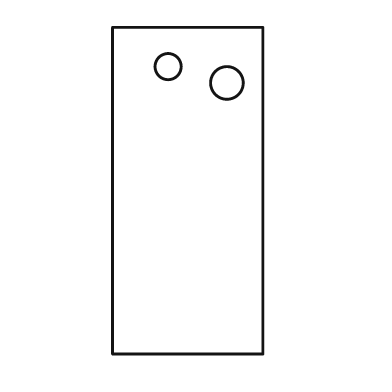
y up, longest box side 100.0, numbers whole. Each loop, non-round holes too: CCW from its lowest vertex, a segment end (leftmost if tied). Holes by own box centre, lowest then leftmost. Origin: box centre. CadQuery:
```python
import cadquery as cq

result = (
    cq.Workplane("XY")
    .moveTo(-23.0, -50.0)
    .lineTo(23.0, -50.0)
    .lineTo(23.0, 50.0)
    .lineTo(-23.0, 50.0)
    .close()
    .moveTo(12.0, 33.0)
    .circle(5.0)
    .moveTo(-6.0, 38.0)
    .circle(4.0)
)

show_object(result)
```